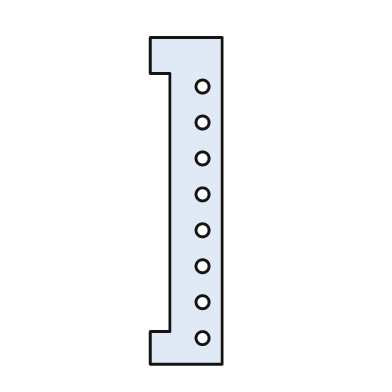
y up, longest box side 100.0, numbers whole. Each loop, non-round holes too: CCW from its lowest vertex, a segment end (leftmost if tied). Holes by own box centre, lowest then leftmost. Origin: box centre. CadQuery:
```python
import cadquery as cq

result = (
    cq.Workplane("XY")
    .moveTo(-11.0, -50.0)
    .lineTo(11.0, -50.0)
    .lineTo(11.0, 50.0)
    .lineTo(-11.0, 50.0)
    .lineTo(-11.0, 39.0)
    .lineTo(-5.0, 39.0)
    .lineTo(-5.0, -40.0)
    .lineTo(-11.0, -40.0)
    .close()
    .moveTo(5.0, -42.0)
    .circle(2.0)
    .moveTo(5.0, -31.0)
    .circle(2.0)
    .moveTo(5.0, -20.0)
    .circle(2.0)
    .moveTo(5.0, -9.0)
    .circle(2.0)
    .moveTo(5.0, 2.0)
    .circle(2.0)
    .moveTo(5.0, 13.0)
    .circle(2.0)
    .moveTo(5.0, 24.0)
    .circle(2.0)
    .moveTo(5.0, 35.0)
    .circle(2.0)
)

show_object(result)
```